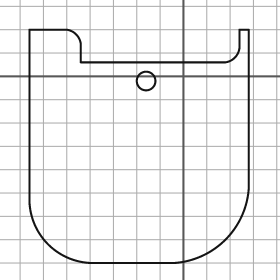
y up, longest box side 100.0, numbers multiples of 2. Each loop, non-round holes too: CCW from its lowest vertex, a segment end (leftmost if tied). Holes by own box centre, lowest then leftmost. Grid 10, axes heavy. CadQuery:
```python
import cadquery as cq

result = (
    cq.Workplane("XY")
    .moveTo(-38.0, -80.0)
    .lineTo(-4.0, -80.0)
    .threePointArc((18.0, -70.0), (28.0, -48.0))
    .lineTo(28.0, 20.0)
    .lineTo(24.0, 20.0)
    .lineTo(24.0, 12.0)
    .threePointArc((22.0, 8.0), (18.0, 6.0))
    .lineTo(-44.0, 6.0)
    .lineTo(-44.0, 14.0)
    .threePointArc((-46.0, 18.0), (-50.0, 20.0))
    .lineTo(-66.0, 20.0)
    .lineTo(-66.0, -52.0)
    .threePointArc((-58.0, -72.0), (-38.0, -80.0))
    .close()
    .moveTo(-16.0, -2.0)
    .circle(4.0)
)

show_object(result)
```